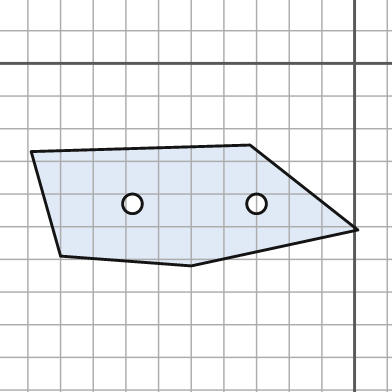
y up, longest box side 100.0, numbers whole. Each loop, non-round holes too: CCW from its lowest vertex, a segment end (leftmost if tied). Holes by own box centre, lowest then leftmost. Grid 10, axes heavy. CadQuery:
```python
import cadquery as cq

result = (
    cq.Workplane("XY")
    .moveTo(-50.0, -62.0)
    .lineTo(1.0, -51.0)
    .lineTo(-32.0, -25.0)
    .lineTo(-99.0, -27.0)
    .lineTo(-90.0, -59.0)
    .close()
    .moveTo(-68.0, -43.0)
    .circle(3.0)
    .moveTo(-30.0, -43.0)
    .circle(3.0)
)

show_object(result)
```